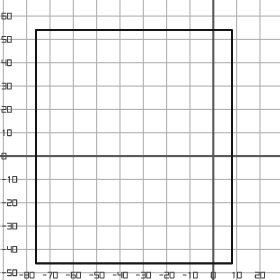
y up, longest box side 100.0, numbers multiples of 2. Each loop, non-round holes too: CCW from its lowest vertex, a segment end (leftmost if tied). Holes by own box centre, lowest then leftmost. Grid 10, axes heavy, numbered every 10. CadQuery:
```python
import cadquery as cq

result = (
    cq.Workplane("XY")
    .moveTo(-76.0, -46.0)
    .lineTo(8.0, -46.0)
    .lineTo(8.0, 54.0)
    .lineTo(-76.0, 54.0)
    .close()
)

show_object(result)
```